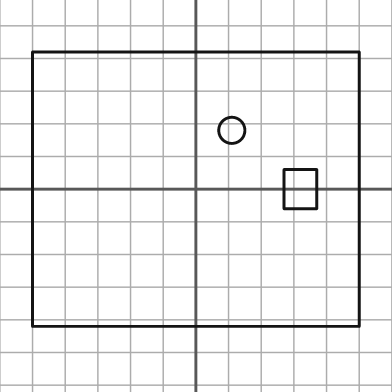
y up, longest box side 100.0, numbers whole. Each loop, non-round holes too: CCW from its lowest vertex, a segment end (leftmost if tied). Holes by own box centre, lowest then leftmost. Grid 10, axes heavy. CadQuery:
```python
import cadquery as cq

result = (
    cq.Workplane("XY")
    .moveTo(-50.0, -42.0)
    .lineTo(50.0, -42.0)
    .lineTo(50.0, 42.0)
    .lineTo(-50.0, 42.0)
    .close()
    .moveTo(27.0, -6.0)
    .lineTo(37.0, -6.0)
    .lineTo(37.0, 6.0)
    .lineTo(27.0, 6.0)
    .close()
    .moveTo(11.0, 18.0)
    .circle(4.0)
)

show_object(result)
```